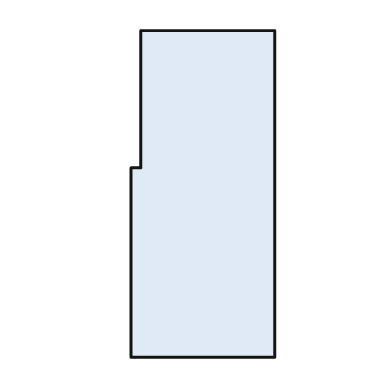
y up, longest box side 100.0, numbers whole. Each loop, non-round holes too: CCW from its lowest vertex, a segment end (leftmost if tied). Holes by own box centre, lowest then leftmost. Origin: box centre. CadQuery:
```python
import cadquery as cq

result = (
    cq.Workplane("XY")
    .moveTo(-22.0, -50.0)
    .lineTo(22.0, -50.0)
    .lineTo(22.0, 50.0)
    .lineTo(-19.0, 50.0)
    .lineTo(-19.0, 8.0)
    .lineTo(-22.0, 8.0)
    .close()
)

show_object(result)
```